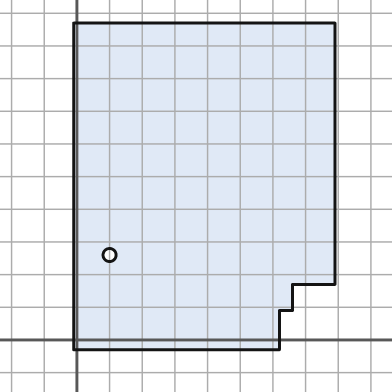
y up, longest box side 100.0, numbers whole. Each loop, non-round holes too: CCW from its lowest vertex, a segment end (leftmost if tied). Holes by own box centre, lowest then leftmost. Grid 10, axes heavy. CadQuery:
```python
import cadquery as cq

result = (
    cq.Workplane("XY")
    .moveTo(-1.0, -3.0)
    .lineTo(62.0, -3.0)
    .lineTo(62.0, 9.0)
    .lineTo(66.0, 9.0)
    .lineTo(66.0, 17.0)
    .lineTo(79.0, 17.0)
    .lineTo(79.0, 97.0)
    .lineTo(-1.0, 97.0)
    .close()
    .moveTo(10.0, 26.0)
    .circle(2.0)
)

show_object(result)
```